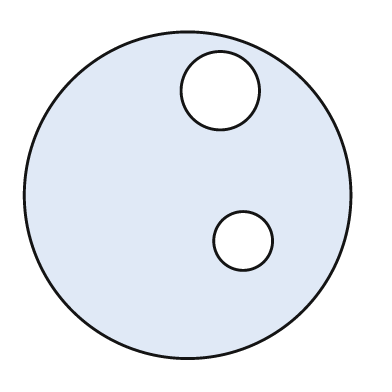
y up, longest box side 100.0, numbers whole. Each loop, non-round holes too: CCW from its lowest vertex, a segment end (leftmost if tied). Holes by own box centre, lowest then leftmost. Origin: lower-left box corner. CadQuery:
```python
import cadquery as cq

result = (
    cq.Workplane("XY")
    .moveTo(50.0, 50.0)
    .circle(50.0)
    .moveTo(67.0, 36.0)
    .circle(9.0)
    .moveTo(60.0, 82.0)
    .circle(12.0)
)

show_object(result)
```